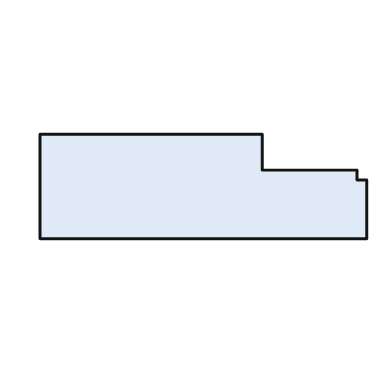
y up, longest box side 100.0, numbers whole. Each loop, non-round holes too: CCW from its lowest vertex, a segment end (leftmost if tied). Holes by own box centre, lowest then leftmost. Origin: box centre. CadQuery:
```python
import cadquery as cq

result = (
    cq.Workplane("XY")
    .moveTo(-50.0, -16.0)
    .lineTo(50.0, -16.0)
    .lineTo(50.0, 2.0)
    .lineTo(47.0, 2.0)
    .lineTo(47.0, 5.0)
    .lineTo(18.0, 5.0)
    .lineTo(18.0, 16.0)
    .lineTo(-50.0, 16.0)
    .close()
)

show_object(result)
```